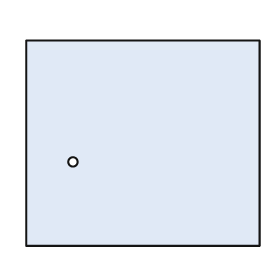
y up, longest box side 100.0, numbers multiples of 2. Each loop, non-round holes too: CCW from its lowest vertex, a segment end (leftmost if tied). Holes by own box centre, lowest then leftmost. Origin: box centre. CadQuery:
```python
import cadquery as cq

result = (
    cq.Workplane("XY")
    .moveTo(-50.0, -44.0)
    .lineTo(50.0, -44.0)
    .lineTo(50.0, 44.0)
    .lineTo(-50.0, 44.0)
    .close()
    .moveTo(-30.0, -8.0)
    .circle(2.0)
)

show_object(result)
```